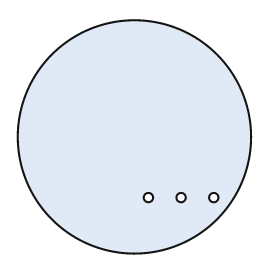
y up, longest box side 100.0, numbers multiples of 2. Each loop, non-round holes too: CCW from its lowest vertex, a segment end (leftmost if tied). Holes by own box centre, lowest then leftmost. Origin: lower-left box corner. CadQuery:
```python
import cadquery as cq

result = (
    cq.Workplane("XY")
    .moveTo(50.0, 50.0)
    .circle(50.0)
    .moveTo(56.0, 24.0)
    .circle(2.0)
    .moveTo(70.0, 24.0)
    .circle(2.0)
    .moveTo(84.0, 24.0)
    .circle(2.0)
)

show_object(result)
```